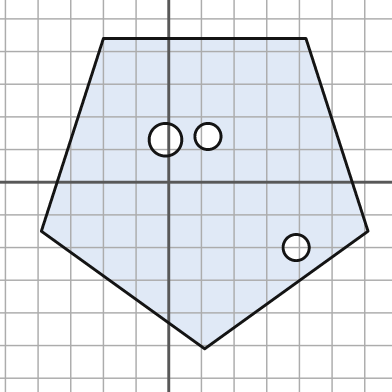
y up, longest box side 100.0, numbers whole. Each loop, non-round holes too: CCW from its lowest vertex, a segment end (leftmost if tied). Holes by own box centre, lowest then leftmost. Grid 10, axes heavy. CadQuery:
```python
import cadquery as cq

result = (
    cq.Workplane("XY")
    .moveTo(11.0, -51.0)
    .lineTo(61.0, -15.0)
    .lineTo(42.0, 44.0)
    .lineTo(-20.0, 44.0)
    .lineTo(-39.0, -15.0)
    .close()
    .moveTo(39.0, -20.0)
    .circle(4.0)
    .moveTo(-1.0, 13.0)
    .circle(5.0)
    .moveTo(12.0, 14.0)
    .circle(4.0)
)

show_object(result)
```